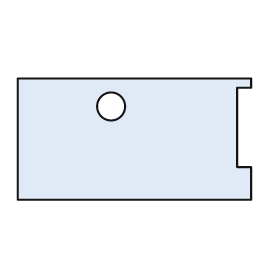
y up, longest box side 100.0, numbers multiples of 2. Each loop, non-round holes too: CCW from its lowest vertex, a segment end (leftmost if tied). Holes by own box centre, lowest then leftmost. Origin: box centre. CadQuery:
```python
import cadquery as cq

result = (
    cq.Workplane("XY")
    .moveTo(-50.0, -26.0)
    .lineTo(50.0, -26.0)
    .lineTo(50.0, -12.0)
    .lineTo(44.0, -12.0)
    .lineTo(44.0, 22.0)
    .lineTo(50.0, 22.0)
    .lineTo(50.0, 26.0)
    .lineTo(-50.0, 26.0)
    .close()
    .moveTo(-10.0, 14.0)
    .circle(6.0)
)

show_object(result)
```